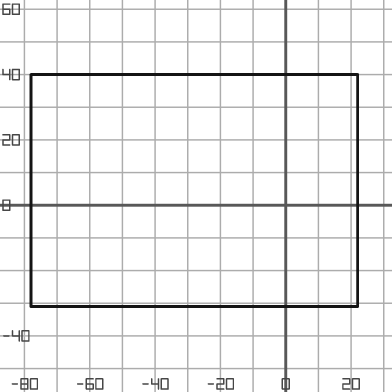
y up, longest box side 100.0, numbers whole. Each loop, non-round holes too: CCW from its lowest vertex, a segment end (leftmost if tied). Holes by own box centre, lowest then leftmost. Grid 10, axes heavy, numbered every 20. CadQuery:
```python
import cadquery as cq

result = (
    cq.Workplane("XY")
    .moveTo(-78.0, -31.0)
    .lineTo(22.0, -31.0)
    .lineTo(22.0, 40.0)
    .lineTo(-78.0, 40.0)
    .close()
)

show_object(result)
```